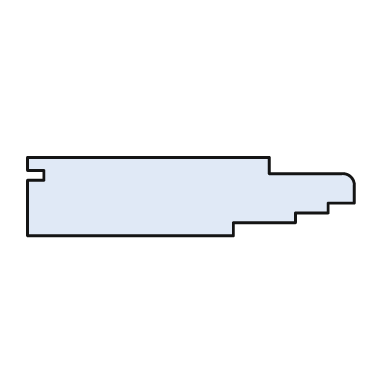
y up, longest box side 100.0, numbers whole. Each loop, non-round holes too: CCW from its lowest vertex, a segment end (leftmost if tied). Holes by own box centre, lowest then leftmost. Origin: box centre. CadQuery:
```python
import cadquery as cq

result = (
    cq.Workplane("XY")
    .moveTo(-50.0, -12.0)
    .lineTo(13.0, -12.0)
    .lineTo(13.0, -8.0)
    .lineTo(32.0, -8.0)
    .lineTo(32.0, -5.0)
    .lineTo(42.0, -5.0)
    .lineTo(42.0, -2.0)
    .lineTo(50.0, -2.0)
    .lineTo(50.0, 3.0)
    .threePointArc((49.0, 6.0), (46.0, 7.0))
    .lineTo(24.0, 7.0)
    .lineTo(24.0, 12.0)
    .lineTo(-50.0, 12.0)
    .lineTo(-50.0, 8.0)
    .lineTo(-45.0, 8.0)
    .lineTo(-45.0, 5.0)
    .lineTo(-50.0, 5.0)
    .close()
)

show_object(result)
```